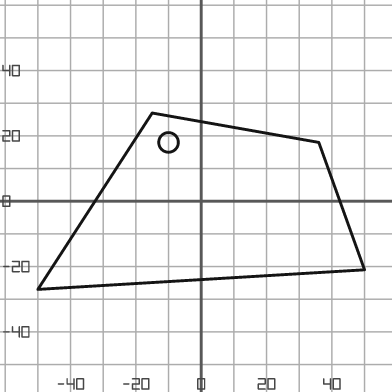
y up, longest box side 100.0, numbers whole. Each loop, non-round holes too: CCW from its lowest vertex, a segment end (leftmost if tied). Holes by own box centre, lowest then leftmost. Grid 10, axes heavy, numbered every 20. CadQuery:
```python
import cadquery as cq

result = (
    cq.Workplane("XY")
    .moveTo(-50.0, -27.0)
    .lineTo(50.0, -21.0)
    .lineTo(36.0, 18.0)
    .lineTo(-15.0, 27.0)
    .close()
    .moveTo(-10.0, 18.0)
    .circle(3.0)
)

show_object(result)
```